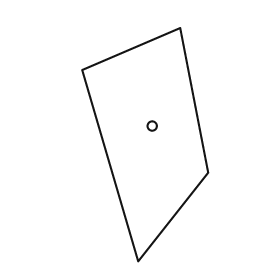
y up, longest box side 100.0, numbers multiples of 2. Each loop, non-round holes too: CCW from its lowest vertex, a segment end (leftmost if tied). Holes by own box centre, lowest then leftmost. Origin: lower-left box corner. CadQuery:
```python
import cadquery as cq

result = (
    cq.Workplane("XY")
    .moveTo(24.0, 0.0)
    .lineTo(54.0, 38.0)
    .lineTo(42.0, 100.0)
    .lineTo(0.0, 82.0)
    .close()
    .moveTo(30.0, 58.0)
    .circle(2.0)
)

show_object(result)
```